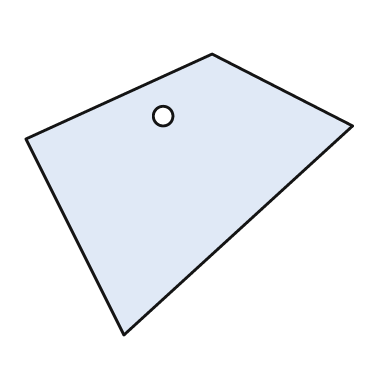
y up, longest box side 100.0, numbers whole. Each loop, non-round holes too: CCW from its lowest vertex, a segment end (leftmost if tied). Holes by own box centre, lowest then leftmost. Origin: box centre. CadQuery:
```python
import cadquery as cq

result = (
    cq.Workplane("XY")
    .moveTo(-20.0, -43.0)
    .lineTo(50.0, 21.0)
    .lineTo(7.0, 43.0)
    .lineTo(-50.0, 17.0)
    .close()
    .moveTo(-8.0, 24.0)
    .circle(3.0)
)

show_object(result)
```